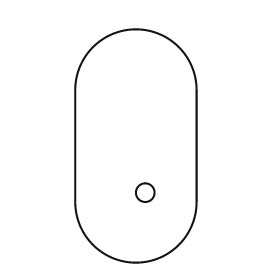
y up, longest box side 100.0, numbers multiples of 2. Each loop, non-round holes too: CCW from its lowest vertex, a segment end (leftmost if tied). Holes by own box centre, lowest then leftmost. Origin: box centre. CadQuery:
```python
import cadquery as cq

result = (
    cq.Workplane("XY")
    .moveTo(-26.0, -24.0)
    .threePointArc((0.0, -50.0), (26.0, -24.0))
    .lineTo(26.0, 24.0)
    .threePointArc((0.0, 50.0), (-26.0, 24.0))
    .close()
    .moveTo(4.0, -20.0)
    .circle(4.0)
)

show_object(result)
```